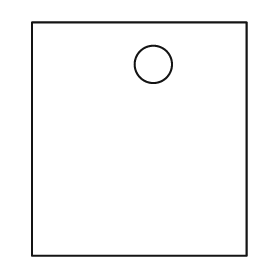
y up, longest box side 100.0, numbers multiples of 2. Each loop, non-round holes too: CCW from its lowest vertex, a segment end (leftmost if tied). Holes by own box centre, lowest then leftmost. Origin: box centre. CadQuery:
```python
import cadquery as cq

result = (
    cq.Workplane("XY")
    .moveTo(-46.0, -50.0)
    .lineTo(46.0, -50.0)
    .lineTo(46.0, 50.0)
    .lineTo(-46.0, 50.0)
    .close()
    .moveTo(6.0, 32.0)
    .circle(8.0)
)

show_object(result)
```